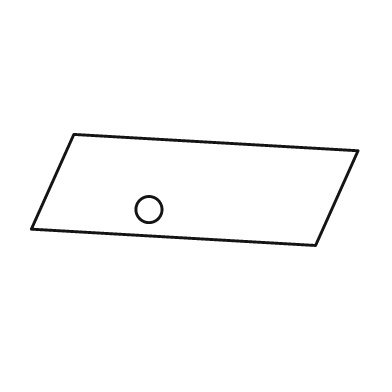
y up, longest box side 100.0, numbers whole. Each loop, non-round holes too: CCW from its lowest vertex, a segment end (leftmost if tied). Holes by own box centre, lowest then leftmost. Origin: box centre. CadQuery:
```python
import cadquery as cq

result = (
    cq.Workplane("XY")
    .moveTo(37.0, -17.0)
    .lineTo(50.0, 12.0)
    .lineTo(-37.0, 17.0)
    .lineTo(-50.0, -12.0)
    .close()
    .moveTo(-14.0, -6.0)
    .circle(4.0)
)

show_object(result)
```